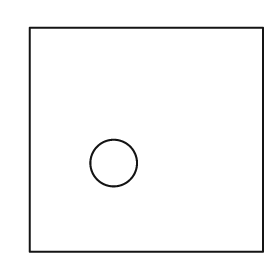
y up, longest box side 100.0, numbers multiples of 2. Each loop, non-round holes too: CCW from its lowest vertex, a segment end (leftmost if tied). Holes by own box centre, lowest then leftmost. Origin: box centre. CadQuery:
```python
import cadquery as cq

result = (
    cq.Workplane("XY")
    .moveTo(-50.0, -48.0)
    .lineTo(50.0, -48.0)
    .lineTo(50.0, 48.0)
    .lineTo(-50.0, 48.0)
    .close()
    .moveTo(-14.0, -10.0)
    .circle(10.0)
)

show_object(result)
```